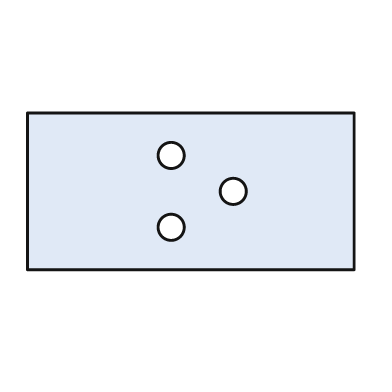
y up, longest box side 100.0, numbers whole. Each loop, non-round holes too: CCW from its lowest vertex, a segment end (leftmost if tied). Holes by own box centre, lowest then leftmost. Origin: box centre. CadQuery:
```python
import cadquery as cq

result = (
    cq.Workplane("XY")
    .moveTo(-50.0, -24.0)
    .lineTo(50.0, -24.0)
    .lineTo(50.0, 24.0)
    .lineTo(-50.0, 24.0)
    .close()
    .moveTo(-6.0, -11.0)
    .circle(4.0)
    .moveTo(13.0, 0.0)
    .circle(4.0)
    .moveTo(-6.0, 11.0)
    .circle(4.0)
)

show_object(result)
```